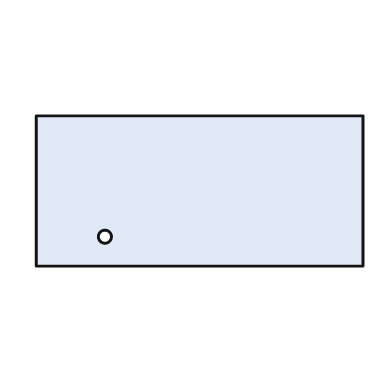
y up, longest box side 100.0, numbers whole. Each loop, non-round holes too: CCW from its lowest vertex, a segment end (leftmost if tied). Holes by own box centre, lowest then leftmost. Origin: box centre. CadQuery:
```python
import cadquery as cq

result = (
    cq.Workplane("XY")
    .moveTo(-50.0, -23.0)
    .lineTo(50.0, -23.0)
    .lineTo(50.0, 23.0)
    .lineTo(-50.0, 23.0)
    .close()
    .moveTo(-29.0, -14.0)
    .circle(2.0)
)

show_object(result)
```